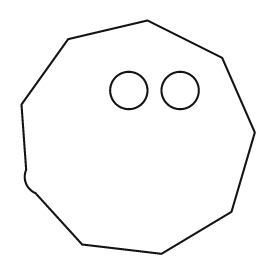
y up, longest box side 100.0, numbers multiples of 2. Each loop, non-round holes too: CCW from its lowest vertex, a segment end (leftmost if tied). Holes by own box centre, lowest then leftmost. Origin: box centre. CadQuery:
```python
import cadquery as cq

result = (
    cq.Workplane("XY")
    .moveTo(10.0, -50.0)
    .lineTo(40.0, -32.0)
    .lineTo(50.0, 2.0)
    .lineTo(36.0, 34.0)
    .lineTo(4.0, 50.0)
    .lineTo(-30.0, 42.0)
    .lineTo(-50.0, 14.0)
    .lineTo(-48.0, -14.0)
    .threePointArc((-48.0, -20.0), (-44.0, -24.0))
    .lineTo(-24.0, -46.0)
    .close()
    .moveTo(-4.0, 20.0)
    .circle(8.0)
    .moveTo(18.0, 20.0)
    .circle(8.0)
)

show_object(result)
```